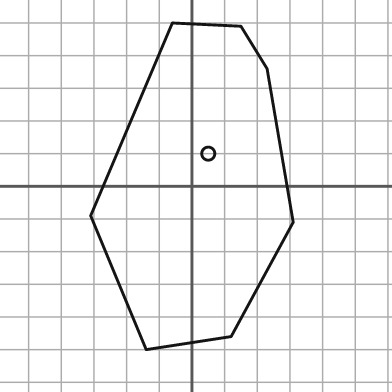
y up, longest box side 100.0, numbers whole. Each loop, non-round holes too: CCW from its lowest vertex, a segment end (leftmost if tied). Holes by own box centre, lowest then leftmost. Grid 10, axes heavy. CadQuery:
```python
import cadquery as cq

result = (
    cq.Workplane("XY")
    .moveTo(-14.0, -50.0)
    .lineTo(12.0, -46.0)
    .lineTo(31.0, -11.0)
    .lineTo(23.0, 36.0)
    .lineTo(15.0, 49.0)
    .lineTo(-6.0, 50.0)
    .lineTo(-31.0, -9.0)
    .close()
    .moveTo(5.0, 10.0)
    .circle(2.0)
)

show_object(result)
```